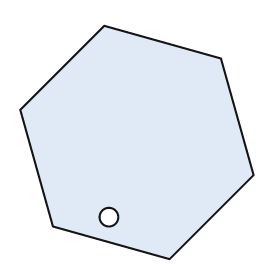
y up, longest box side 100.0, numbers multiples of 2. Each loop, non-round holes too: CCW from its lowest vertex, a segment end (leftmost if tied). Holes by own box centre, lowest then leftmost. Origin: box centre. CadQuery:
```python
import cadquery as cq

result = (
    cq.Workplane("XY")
    .moveTo(14.0, -50.0)
    .lineTo(50.0, -14.0)
    .lineTo(36.0, 36.0)
    .lineTo(-14.0, 50.0)
    .lineTo(-50.0, 14.0)
    .lineTo(-36.0, -36.0)
    .close()
    .moveTo(-12.0, -32.0)
    .circle(4.0)
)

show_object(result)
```